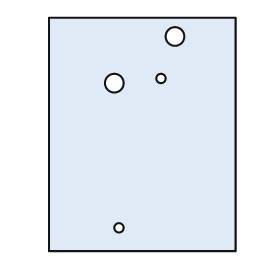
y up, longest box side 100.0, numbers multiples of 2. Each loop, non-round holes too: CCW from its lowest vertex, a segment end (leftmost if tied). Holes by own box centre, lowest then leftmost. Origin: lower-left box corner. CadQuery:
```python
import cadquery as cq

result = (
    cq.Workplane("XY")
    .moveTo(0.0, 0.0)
    .lineTo(80.0, 0.0)
    .lineTo(80.0, 100.0)
    .lineTo(0.0, 100.0)
    .close()
    .moveTo(30.0, 10.0)
    .circle(2.0)
    .moveTo(28.0, 72.0)
    .circle(4.0)
    .moveTo(48.0, 74.0)
    .circle(2.0)
    .moveTo(54.0, 92.0)
    .circle(4.0)
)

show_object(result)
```